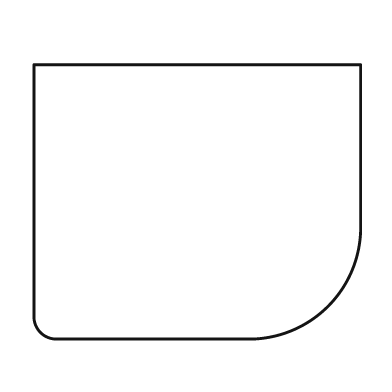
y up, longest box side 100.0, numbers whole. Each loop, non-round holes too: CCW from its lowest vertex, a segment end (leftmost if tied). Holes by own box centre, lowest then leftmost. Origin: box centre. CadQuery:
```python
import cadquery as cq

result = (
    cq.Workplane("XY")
    .moveTo(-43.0, -42.0)
    .lineTo(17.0, -42.0)
    .threePointArc((40.0, -32.0), (50.0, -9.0))
    .lineTo(50.0, 42.0)
    .lineTo(-50.0, 42.0)
    .lineTo(-50.0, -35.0)
    .threePointArc((-48.0, -40.0), (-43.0, -42.0))
    .close()
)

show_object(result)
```